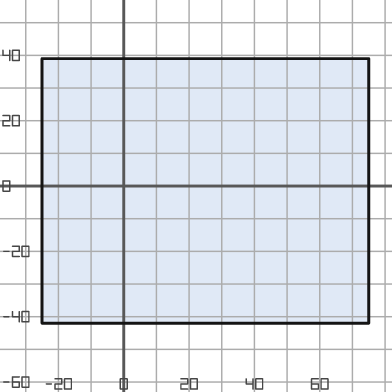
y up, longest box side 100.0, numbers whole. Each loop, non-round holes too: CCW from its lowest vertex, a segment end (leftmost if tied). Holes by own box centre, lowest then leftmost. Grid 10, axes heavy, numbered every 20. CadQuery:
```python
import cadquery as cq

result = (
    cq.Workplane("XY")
    .moveTo(-25.0, -42.0)
    .lineTo(75.0, -42.0)
    .lineTo(75.0, 39.0)
    .lineTo(-25.0, 39.0)
    .close()
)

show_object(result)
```